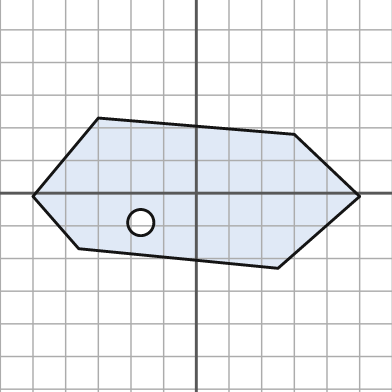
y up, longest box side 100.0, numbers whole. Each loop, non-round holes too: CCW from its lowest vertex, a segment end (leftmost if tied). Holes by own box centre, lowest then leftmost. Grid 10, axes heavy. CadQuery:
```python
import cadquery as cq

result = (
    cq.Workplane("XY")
    .moveTo(25.0, -23.0)
    .lineTo(50.0, -1.0)
    .lineTo(30.0, 18.0)
    .lineTo(-30.0, 23.0)
    .lineTo(-50.0, -1.0)
    .lineTo(-36.0, -17.0)
    .close()
    .moveTo(-17.0, -9.0)
    .circle(4.0)
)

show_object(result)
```